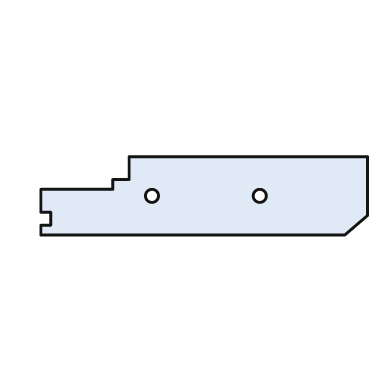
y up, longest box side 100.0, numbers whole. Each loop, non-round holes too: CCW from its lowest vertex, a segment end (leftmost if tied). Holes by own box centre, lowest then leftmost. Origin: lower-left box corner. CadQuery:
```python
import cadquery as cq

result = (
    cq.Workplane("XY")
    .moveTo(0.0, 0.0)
    .lineTo(93.0, 0.0)
    .lineTo(100.0, 6.0)
    .lineTo(100.0, 24.0)
    .lineTo(27.0, 24.0)
    .lineTo(27.0, 17.0)
    .lineTo(22.0, 17.0)
    .lineTo(22.0, 14.0)
    .lineTo(0.0, 14.0)
    .lineTo(0.0, 7.0)
    .lineTo(3.0, 7.0)
    .lineTo(3.0, 3.0)
    .lineTo(0.0, 3.0)
    .close()
    .moveTo(34.0, 12.0)
    .circle(2.0)
    .moveTo(67.0, 12.0)
    .circle(2.0)
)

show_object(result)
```